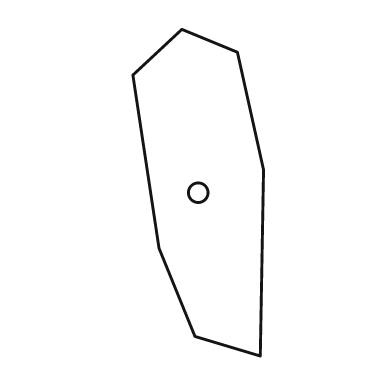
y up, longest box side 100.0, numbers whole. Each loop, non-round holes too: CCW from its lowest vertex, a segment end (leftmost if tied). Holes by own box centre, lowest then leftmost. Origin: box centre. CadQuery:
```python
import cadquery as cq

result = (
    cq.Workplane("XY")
    .moveTo(19.0, -50.0)
    .lineTo(20.0, 7.0)
    .lineTo(12.0, 43.0)
    .lineTo(-5.0, 50.0)
    .lineTo(-20.0, 36.0)
    .lineTo(-12.0, -17.0)
    .lineTo(-1.0, -44.0)
    .close()
    .moveTo(0.0, 0.0)
    .circle(3.0)
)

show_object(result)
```